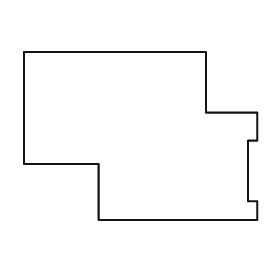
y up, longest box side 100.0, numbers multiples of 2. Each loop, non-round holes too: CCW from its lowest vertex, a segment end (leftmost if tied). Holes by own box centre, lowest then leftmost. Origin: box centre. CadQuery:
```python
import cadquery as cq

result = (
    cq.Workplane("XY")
    .moveTo(-18.0, -36.0)
    .lineTo(50.0, -36.0)
    .lineTo(50.0, -28.0)
    .lineTo(46.0, -28.0)
    .lineTo(46.0, -2.0)
    .lineTo(50.0, -2.0)
    .lineTo(50.0, 10.0)
    .lineTo(28.0, 10.0)
    .lineTo(28.0, 36.0)
    .lineTo(-50.0, 36.0)
    .lineTo(-50.0, -12.0)
    .lineTo(-18.0, -12.0)
    .close()
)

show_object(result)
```